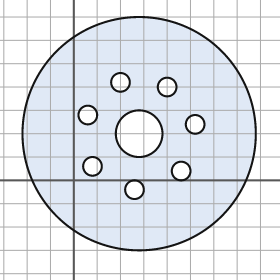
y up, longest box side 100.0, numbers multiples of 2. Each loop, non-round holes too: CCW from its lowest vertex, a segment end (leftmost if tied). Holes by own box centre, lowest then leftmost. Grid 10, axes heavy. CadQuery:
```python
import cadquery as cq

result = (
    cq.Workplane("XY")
    .moveTo(28.0, 20.0)
    .circle(50.0)
    .moveTo(26.0, -4.0)
    .circle(4.0)
    .moveTo(46.0, 4.0)
    .circle(4.0)
    .moveTo(8.0, 6.0)
    .circle(4.0)
    .moveTo(28.0, 20.0)
    .circle(10.0)
    .moveTo(52.0, 24.0)
    .circle(4.0)
    .moveTo(6.0, 28.0)
    .circle(4.0)
    .moveTo(40.0, 40.0)
    .circle(4.0)
    .moveTo(20.0, 42.0)
    .circle(4.0)
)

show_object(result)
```